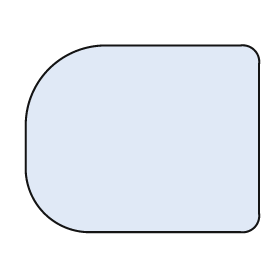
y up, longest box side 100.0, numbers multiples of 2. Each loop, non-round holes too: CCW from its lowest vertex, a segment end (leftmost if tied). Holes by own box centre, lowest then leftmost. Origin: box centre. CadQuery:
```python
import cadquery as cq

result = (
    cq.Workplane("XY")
    .moveTo(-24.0, -40.0)
    .lineTo(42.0, -40.0)
    .threePointArc((48.0, -38.0), (50.0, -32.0))
    .lineTo(50.0, 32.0)
    .threePointArc((48.0, 38.0), (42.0, 40.0))
    .lineTo(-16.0, 40.0)
    .threePointArc((-40.0, 30.0), (-50.0, 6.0))
    .lineTo(-50.0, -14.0)
    .threePointArc((-42.0, -32.0), (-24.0, -40.0))
    .close()
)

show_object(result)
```